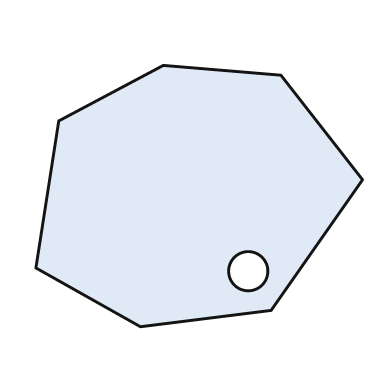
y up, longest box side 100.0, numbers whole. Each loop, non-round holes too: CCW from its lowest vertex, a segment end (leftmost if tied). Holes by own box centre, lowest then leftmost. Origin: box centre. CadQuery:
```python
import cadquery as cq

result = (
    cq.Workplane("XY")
    .moveTo(-18.0, -40.0)
    .lineTo(22.0, -35.0)
    .lineTo(50.0, 5.0)
    .lineTo(25.0, 37.0)
    .lineTo(-11.0, 40.0)
    .lineTo(-43.0, 23.0)
    .lineTo(-50.0, -22.0)
    .close()
    .moveTo(15.0, -23.0)
    .circle(6.0)
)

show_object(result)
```